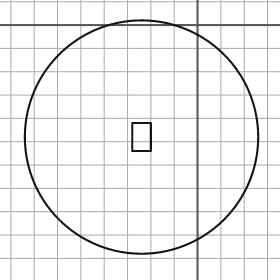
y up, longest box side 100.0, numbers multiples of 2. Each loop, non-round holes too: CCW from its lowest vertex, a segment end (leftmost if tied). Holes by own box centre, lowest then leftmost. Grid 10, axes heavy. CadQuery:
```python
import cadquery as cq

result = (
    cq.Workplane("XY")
    .moveTo(-24.0, -48.0)
    .circle(50.0)
    .moveTo(-28.0, -54.0)
    .lineTo(-20.0, -54.0)
    .lineTo(-20.0, -42.0)
    .lineTo(-28.0, -42.0)
    .close()
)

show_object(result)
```